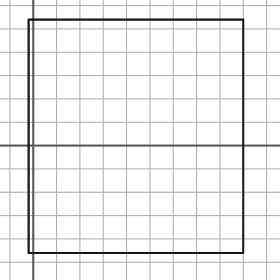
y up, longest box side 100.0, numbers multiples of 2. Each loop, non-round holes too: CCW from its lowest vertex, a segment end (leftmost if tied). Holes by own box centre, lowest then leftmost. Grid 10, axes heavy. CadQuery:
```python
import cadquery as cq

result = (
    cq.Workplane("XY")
    .moveTo(-2.0, -46.0)
    .lineTo(90.0, -46.0)
    .lineTo(90.0, 54.0)
    .lineTo(-2.0, 54.0)
    .close()
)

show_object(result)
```